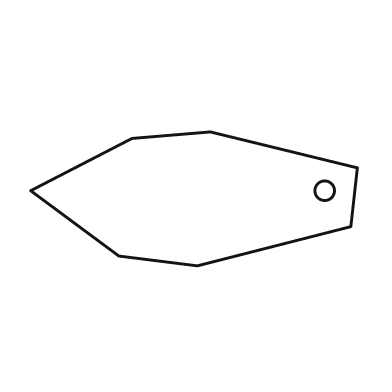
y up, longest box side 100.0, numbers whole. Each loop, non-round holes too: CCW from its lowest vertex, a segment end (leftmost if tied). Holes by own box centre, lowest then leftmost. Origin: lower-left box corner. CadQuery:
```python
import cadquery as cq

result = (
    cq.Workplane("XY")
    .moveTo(51.0, 0.0)
    .lineTo(98.0, 12.0)
    .lineTo(100.0, 30.0)
    .lineTo(55.0, 41.0)
    .lineTo(31.0, 39.0)
    .lineTo(0.0, 23.0)
    .lineTo(27.0, 3.0)
    .close()
    .moveTo(90.0, 23.0)
    .circle(3.0)
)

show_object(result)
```